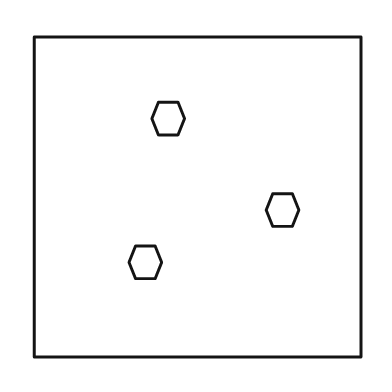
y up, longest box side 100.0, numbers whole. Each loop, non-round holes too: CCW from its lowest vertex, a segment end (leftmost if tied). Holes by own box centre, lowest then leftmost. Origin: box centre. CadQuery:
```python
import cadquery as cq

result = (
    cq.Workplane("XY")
    .moveTo(-50.0, -49.0)
    .lineTo(50.0, -49.0)
    .lineTo(50.0, 49.0)
    .lineTo(-50.0, 49.0)
    .close()
    .moveTo(-19.0, -25.0)
    .lineTo(-13.0, -25.0)
    .lineTo(-11.0, -20.0)
    .lineTo(-13.0, -15.0)
    .lineTo(-19.0, -15.0)
    .lineTo(-21.0, -20.0)
    .close()
    .moveTo(23.0, -9.0)
    .lineTo(29.0, -9.0)
    .lineTo(31.0, -4.0)
    .lineTo(29.0, 1.0)
    .lineTo(23.0, 1.0)
    .lineTo(21.0, -4.0)
    .close()
    .moveTo(-12.0, 19.0)
    .lineTo(-6.0, 19.0)
    .lineTo(-4.0, 24.0)
    .lineTo(-6.0, 29.0)
    .lineTo(-12.0, 29.0)
    .lineTo(-14.0, 24.0)
    .close()
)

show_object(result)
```